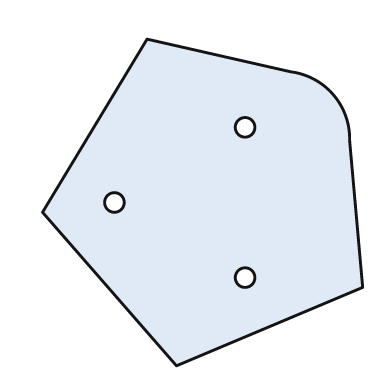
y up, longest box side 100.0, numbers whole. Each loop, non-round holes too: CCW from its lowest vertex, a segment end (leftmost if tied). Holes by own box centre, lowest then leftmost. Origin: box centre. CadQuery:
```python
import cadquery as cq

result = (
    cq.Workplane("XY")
    .moveTo(-8.0, -50.0)
    .lineTo(49.0, -26.0)
    .lineTo(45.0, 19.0)
    .threePointArc((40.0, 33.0), (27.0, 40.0))
    .lineTo(-17.0, 50.0)
    .lineTo(-49.0, -3.0)
    .close()
    .moveTo(13.0, -23.0)
    .circle(3.0)
    .moveTo(-27.0, 0.0)
    .circle(3.0)
    .moveTo(13.0, 23.0)
    .circle(3.0)
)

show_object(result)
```